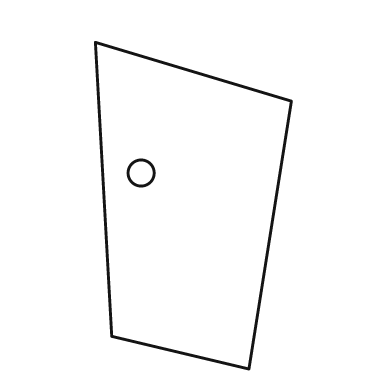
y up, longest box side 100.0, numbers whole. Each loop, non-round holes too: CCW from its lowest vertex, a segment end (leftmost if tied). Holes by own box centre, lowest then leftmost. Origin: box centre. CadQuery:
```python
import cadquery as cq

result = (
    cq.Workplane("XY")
    .moveTo(17.0, -50.0)
    .lineTo(30.0, 32.0)
    .lineTo(-30.0, 50.0)
    .lineTo(-25.0, -40.0)
    .close()
    .moveTo(-16.0, 10.0)
    .circle(4.0)
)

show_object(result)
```